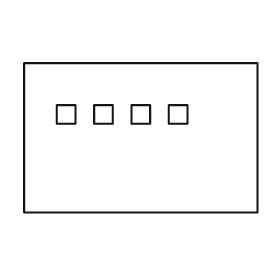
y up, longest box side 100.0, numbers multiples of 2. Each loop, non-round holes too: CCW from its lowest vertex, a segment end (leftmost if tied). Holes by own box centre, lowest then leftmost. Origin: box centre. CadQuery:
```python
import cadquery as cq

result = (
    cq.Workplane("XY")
    .moveTo(-50.0, -32.0)
    .lineTo(50.0, -32.0)
    .lineTo(50.0, 32.0)
    .lineTo(-50.0, 32.0)
    .close()
    .moveTo(-36.0, 6.0)
    .lineTo(-28.0, 6.0)
    .lineTo(-28.0, 14.0)
    .lineTo(-36.0, 14.0)
    .close()
    .moveTo(-20.0, 6.0)
    .lineTo(-12.0, 6.0)
    .lineTo(-12.0, 14.0)
    .lineTo(-20.0, 14.0)
    .close()
    .moveTo(-4.0, 6.0)
    .lineTo(4.0, 6.0)
    .lineTo(4.0, 14.0)
    .lineTo(-4.0, 14.0)
    .close()
    .moveTo(12.0, 6.0)
    .lineTo(20.0, 6.0)
    .lineTo(20.0, 14.0)
    .lineTo(12.0, 14.0)
    .close()
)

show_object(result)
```